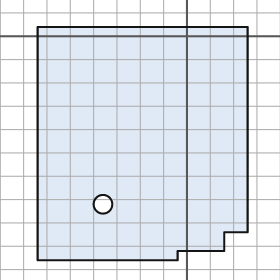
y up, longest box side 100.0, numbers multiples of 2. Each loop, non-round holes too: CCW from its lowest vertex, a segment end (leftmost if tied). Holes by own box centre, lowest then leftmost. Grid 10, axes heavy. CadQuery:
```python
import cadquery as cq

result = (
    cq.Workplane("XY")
    .moveTo(-64.0, -96.0)
    .lineTo(-4.0, -96.0)
    .lineTo(-4.0, -92.0)
    .lineTo(16.0, -92.0)
    .lineTo(16.0, -84.0)
    .lineTo(26.0, -84.0)
    .lineTo(26.0, 4.0)
    .lineTo(-64.0, 4.0)
    .close()
    .moveTo(-36.0, -72.0)
    .circle(4.0)
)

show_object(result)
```